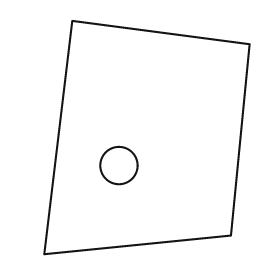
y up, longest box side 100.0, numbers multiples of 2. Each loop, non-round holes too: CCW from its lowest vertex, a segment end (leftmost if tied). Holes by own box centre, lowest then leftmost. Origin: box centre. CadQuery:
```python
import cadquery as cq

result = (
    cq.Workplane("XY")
    .moveTo(-44.0, -50.0)
    .lineTo(36.0, -42.0)
    .lineTo(44.0, 40.0)
    .lineTo(-32.0, 50.0)
    .close()
    .moveTo(-12.0, -12.0)
    .circle(8.0)
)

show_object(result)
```